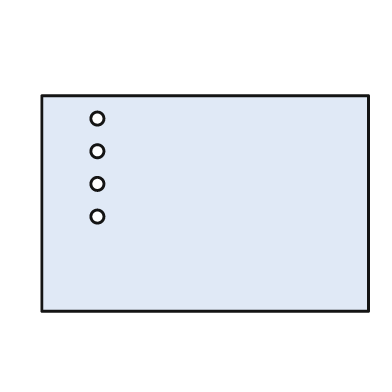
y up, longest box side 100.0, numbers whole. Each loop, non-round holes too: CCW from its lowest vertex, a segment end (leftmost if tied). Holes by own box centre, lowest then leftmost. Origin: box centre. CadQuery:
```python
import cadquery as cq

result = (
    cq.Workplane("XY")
    .moveTo(-50.0, -33.0)
    .lineTo(50.0, -33.0)
    .lineTo(50.0, 33.0)
    .lineTo(-50.0, 33.0)
    .close()
    .moveTo(-33.0, -4.0)
    .circle(2.0)
    .moveTo(-33.0, 6.0)
    .circle(2.0)
    .moveTo(-33.0, 16.0)
    .circle(2.0)
    .moveTo(-33.0, 26.0)
    .circle(2.0)
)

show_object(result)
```